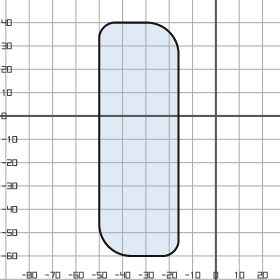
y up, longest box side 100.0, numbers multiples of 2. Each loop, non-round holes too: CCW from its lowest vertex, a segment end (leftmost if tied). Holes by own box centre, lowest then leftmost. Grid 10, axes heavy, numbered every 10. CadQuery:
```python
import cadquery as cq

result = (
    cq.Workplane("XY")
    .moveTo(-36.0, -60.0)
    .lineTo(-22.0, -60.0)
    .threePointArc((-18.0, -58.0), (-16.0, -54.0))
    .lineTo(-16.0, 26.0)
    .threePointArc((-20.0, 36.0), (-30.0, 40.0))
    .lineTo(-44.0, 40.0)
    .threePointArc((-48.0, 38.0), (-50.0, 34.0))
    .lineTo(-50.0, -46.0)
    .threePointArc((-46.0, -56.0), (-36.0, -60.0))
    .close()
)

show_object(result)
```